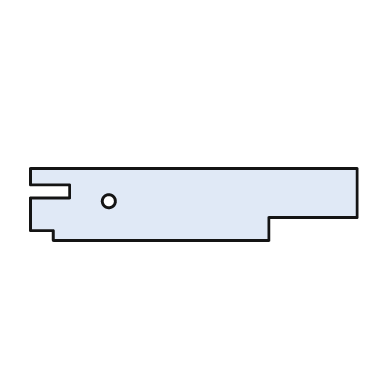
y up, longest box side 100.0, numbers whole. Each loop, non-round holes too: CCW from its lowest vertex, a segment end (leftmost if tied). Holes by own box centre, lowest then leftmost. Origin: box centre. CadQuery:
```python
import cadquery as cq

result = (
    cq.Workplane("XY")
    .moveTo(-43.0, -11.0)
    .lineTo(23.0, -11.0)
    .lineTo(23.0, -4.0)
    .lineTo(50.0, -4.0)
    .lineTo(50.0, 11.0)
    .lineTo(-50.0, 11.0)
    .lineTo(-50.0, 6.0)
    .lineTo(-38.0, 6.0)
    .lineTo(-38.0, 2.0)
    .lineTo(-50.0, 2.0)
    .lineTo(-50.0, -8.0)
    .lineTo(-43.0, -8.0)
    .close()
    .moveTo(-26.0, 1.0)
    .circle(2.0)
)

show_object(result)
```